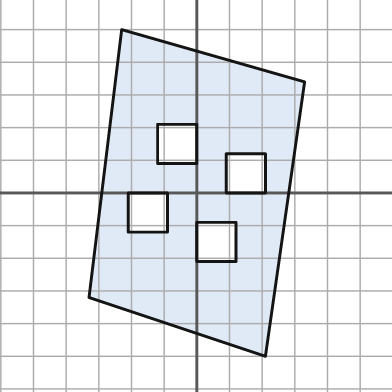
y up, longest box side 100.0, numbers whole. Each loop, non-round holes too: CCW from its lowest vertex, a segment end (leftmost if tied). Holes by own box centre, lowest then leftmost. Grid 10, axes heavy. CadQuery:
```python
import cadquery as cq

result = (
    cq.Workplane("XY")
    .moveTo(21.0, -50.0)
    .lineTo(33.0, 34.0)
    .lineTo(-23.0, 50.0)
    .lineTo(-33.0, -32.0)
    .close()
    .moveTo(0.0, -21.0)
    .lineTo(12.0, -21.0)
    .lineTo(12.0, -9.0)
    .lineTo(0.0, -9.0)
    .close()
    .moveTo(-21.0, -12.0)
    .lineTo(-9.0, -12.0)
    .lineTo(-9.0, 0.0)
    .lineTo(-21.0, 0.0)
    .close()
    .moveTo(9.0, 0.0)
    .lineTo(21.0, 0.0)
    .lineTo(21.0, 12.0)
    .lineTo(9.0, 12.0)
    .close()
    .moveTo(-12.0, 9.0)
    .lineTo(0.0, 9.0)
    .lineTo(0.0, 21.0)
    .lineTo(-12.0, 21.0)
    .close()
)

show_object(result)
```